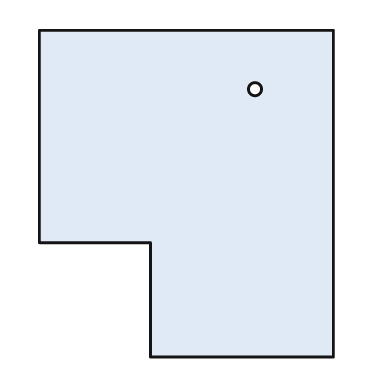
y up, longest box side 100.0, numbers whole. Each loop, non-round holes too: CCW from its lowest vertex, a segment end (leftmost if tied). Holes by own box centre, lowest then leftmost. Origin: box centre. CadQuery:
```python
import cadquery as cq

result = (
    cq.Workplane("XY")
    .moveTo(-11.0, -50.0)
    .lineTo(45.0, -50.0)
    .lineTo(45.0, 50.0)
    .lineTo(-45.0, 50.0)
    .lineTo(-45.0, -15.0)
    .lineTo(-11.0, -15.0)
    .close()
    .moveTo(21.0, 32.0)
    .circle(2.0)
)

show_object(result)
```